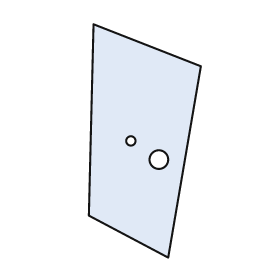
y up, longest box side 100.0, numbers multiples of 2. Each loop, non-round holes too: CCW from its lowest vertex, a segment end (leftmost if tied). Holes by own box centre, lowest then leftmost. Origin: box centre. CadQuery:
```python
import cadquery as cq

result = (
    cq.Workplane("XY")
    .moveTo(10.0, -50.0)
    .lineTo(24.0, 32.0)
    .lineTo(-22.0, 50.0)
    .lineTo(-24.0, -32.0)
    .close()
    .moveTo(6.0, -8.0)
    .circle(4.0)
    .moveTo(-6.0, 0.0)
    .circle(2.0)
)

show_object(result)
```